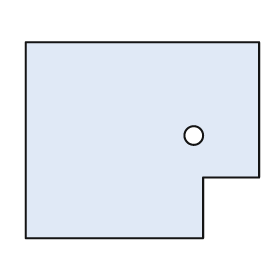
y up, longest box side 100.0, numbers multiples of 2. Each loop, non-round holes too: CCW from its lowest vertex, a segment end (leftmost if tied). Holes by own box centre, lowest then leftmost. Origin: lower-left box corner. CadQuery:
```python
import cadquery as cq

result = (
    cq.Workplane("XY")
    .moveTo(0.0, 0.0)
    .lineTo(76.0, 0.0)
    .lineTo(76.0, 26.0)
    .lineTo(100.0, 26.0)
    .lineTo(100.0, 84.0)
    .lineTo(0.0, 84.0)
    .close()
    .moveTo(72.0, 44.0)
    .circle(4.0)
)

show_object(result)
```